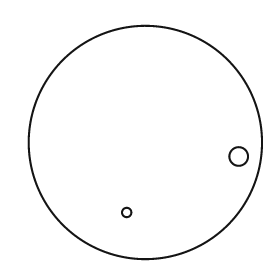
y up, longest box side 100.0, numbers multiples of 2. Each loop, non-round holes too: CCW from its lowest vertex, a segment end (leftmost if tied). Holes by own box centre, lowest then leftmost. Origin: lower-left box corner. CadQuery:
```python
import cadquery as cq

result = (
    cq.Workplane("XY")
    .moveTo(50.0, 50.0)
    .circle(50.0)
    .moveTo(42.0, 20.0)
    .circle(2.0)
    .moveTo(90.0, 44.0)
    .circle(4.0)
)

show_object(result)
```